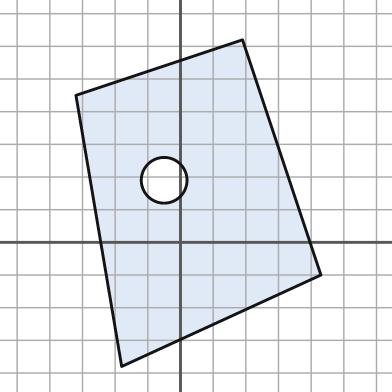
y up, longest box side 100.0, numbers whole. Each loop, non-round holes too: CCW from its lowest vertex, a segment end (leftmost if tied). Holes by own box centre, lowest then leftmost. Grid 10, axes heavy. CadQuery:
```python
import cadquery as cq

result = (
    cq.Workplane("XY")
    .moveTo(-18.0, -38.0)
    .lineTo(43.0, -10.0)
    .lineTo(19.0, 62.0)
    .lineTo(-32.0, 45.0)
    .close()
    .moveTo(-5.0, 19.0)
    .circle(7.0)
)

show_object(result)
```